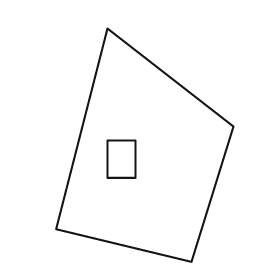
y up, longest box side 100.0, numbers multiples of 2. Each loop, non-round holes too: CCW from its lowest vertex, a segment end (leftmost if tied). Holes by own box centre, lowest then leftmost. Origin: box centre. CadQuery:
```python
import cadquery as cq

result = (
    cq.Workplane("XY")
    .moveTo(20.0, -50.0)
    .lineTo(38.0, 8.0)
    .lineTo(-16.0, 50.0)
    .lineTo(-38.0, -36.0)
    .close()
    .moveTo(-16.0, -14.0)
    .lineTo(-4.0, -14.0)
    .lineTo(-4.0, 2.0)
    .lineTo(-16.0, 2.0)
    .close()
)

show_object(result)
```